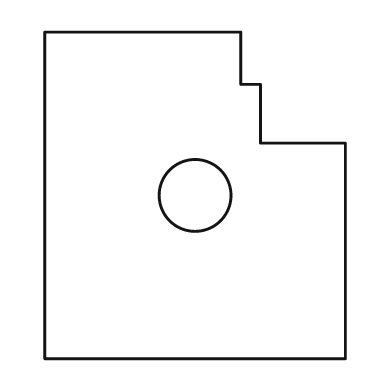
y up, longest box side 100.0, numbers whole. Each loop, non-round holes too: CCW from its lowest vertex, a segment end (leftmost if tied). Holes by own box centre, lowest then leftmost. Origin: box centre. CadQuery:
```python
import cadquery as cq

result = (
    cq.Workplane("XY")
    .moveTo(-46.0, -50.0)
    .lineTo(46.0, -50.0)
    .lineTo(46.0, 16.0)
    .lineTo(20.0, 16.0)
    .lineTo(20.0, 34.0)
    .lineTo(14.0, 34.0)
    .lineTo(14.0, 50.0)
    .lineTo(-46.0, 50.0)
    .close()
    .moveTo(0.0, 0.0)
    .circle(11.0)
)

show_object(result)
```